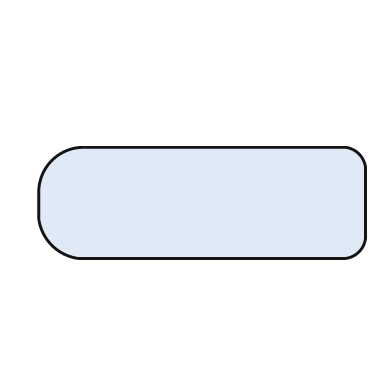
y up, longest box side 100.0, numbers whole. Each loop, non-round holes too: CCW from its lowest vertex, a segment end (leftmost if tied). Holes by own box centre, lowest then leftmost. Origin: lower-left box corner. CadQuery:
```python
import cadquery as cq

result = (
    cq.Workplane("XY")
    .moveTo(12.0, 0.0)
    .lineTo(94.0, 0.0)
    .threePointArc((98.0, 2.0), (100.0, 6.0))
    .lineTo(100.0, 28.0)
    .threePointArc((98.0, 32.0), (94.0, 34.0))
    .lineTo(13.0, 34.0)
    .threePointArc((4.0, 30.0), (0.0, 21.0))
    .lineTo(0.0, 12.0)
    .threePointArc((4.0, 4.0), (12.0, 0.0))
    .close()
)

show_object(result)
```